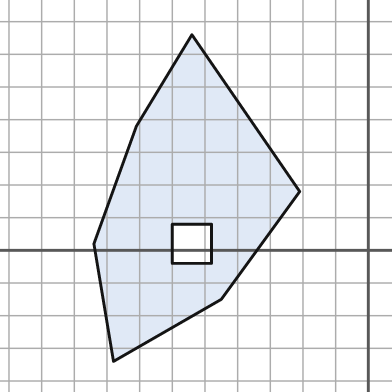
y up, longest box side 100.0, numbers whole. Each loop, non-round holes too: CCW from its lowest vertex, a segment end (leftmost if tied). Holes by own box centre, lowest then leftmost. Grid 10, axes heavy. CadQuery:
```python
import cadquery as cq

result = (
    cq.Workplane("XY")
    .moveTo(-78.0, -34.0)
    .lineTo(-45.0, -15.0)
    .lineTo(-21.0, 18.0)
    .lineTo(-54.0, 66.0)
    .lineTo(-71.0, 38.0)
    .lineTo(-84.0, 2.0)
    .close()
    .moveTo(-60.0, -4.0)
    .lineTo(-48.0, -4.0)
    .lineTo(-48.0, 8.0)
    .lineTo(-60.0, 8.0)
    .close()
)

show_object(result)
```